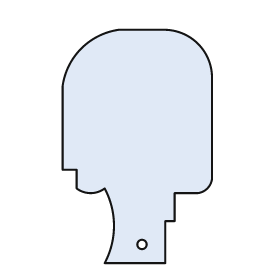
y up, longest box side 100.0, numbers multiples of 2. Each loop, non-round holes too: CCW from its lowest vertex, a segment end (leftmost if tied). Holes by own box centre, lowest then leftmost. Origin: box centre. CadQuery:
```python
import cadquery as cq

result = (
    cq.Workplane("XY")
    .moveTo(-14.0, -50.0)
    .lineTo(12.0, -50.0)
    .lineTo(12.0, -32.0)
    .lineTo(16.0, -32.0)
    .lineTo(16.0, -20.0)
    .lineTo(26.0, -20.0)
    .threePointArc((30.0, -18.0), (32.0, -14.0))
    .lineTo(32.0, 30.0)
    .threePointArc((26.0, 44.0), (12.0, 50.0))
    .lineTo(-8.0, 50.0)
    .threePointArc((-24.0, 42.0), (-32.0, 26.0))
    .lineTo(-32.0, -10.0)
    .lineTo(-26.0, -10.0)
    .lineTo(-26.0, -18.0)
    .threePointArc((-20.0, -20.0), (-14.0, -18.0))
    .threePointArc((-10.0, -34.0), (-14.0, -50.0))
    .close()
    .moveTo(2.0, -42.0)
    .circle(2.0)
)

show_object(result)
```